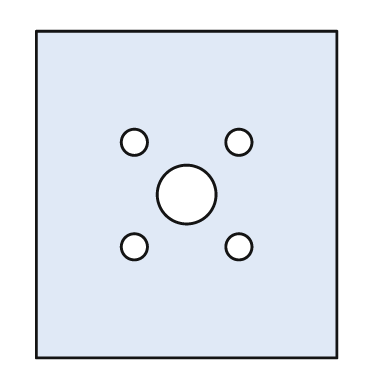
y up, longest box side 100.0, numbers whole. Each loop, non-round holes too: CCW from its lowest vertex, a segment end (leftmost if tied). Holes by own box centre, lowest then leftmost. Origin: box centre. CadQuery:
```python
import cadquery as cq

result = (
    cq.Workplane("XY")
    .moveTo(-46.0, -50.0)
    .lineTo(46.0, -50.0)
    .lineTo(46.0, 50.0)
    .lineTo(-46.0, 50.0)
    .close()
    .moveTo(-16.0, -16.0)
    .circle(4.0)
    .moveTo(16.0, -16.0)
    .circle(4.0)
    .moveTo(0.0, 0.0)
    .circle(9.0)
    .moveTo(-16.0, 16.0)
    .circle(4.0)
    .moveTo(16.0, 16.0)
    .circle(4.0)
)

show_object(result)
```